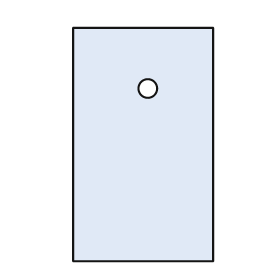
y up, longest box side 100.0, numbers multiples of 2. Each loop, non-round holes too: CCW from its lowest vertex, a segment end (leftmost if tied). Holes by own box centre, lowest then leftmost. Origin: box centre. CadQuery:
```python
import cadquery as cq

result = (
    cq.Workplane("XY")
    .moveTo(-30.0, -50.0)
    .lineTo(30.0, -50.0)
    .lineTo(30.0, 50.0)
    .lineTo(-30.0, 50.0)
    .close()
    .moveTo(2.0, 24.0)
    .circle(4.0)
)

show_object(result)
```